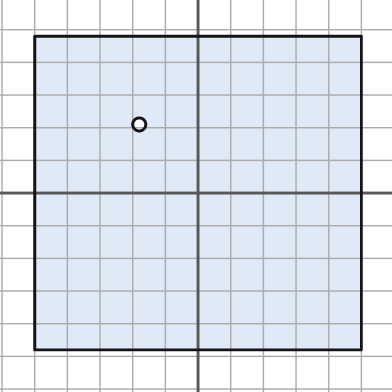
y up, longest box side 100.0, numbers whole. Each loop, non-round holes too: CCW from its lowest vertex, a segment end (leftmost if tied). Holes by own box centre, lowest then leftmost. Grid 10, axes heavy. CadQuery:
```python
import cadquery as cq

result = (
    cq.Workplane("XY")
    .moveTo(-50.0, -48.0)
    .lineTo(50.0, -48.0)
    .lineTo(50.0, 48.0)
    .lineTo(-50.0, 48.0)
    .close()
    .moveTo(-18.0, 21.0)
    .circle(2.0)
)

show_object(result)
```